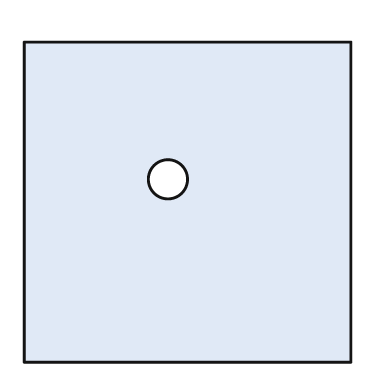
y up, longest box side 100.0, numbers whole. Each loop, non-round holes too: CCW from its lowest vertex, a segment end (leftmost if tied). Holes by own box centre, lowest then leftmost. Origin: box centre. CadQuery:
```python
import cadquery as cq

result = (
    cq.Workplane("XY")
    .moveTo(-50.0, -49.0)
    .lineTo(50.0, -49.0)
    .lineTo(50.0, 49.0)
    .lineTo(-50.0, 49.0)
    .close()
    .moveTo(-6.0, 7.0)
    .circle(6.0)
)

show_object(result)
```